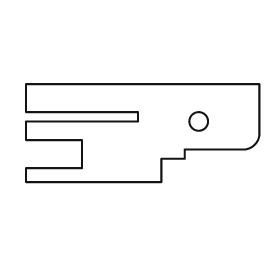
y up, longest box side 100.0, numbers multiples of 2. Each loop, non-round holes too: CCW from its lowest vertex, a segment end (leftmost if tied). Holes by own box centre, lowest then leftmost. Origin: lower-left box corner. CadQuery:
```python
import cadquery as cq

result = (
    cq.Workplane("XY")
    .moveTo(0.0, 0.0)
    .lineTo(58.0, 0.0)
    .lineTo(58.0, 10.0)
    .lineTo(68.0, 10.0)
    .lineTo(68.0, 14.0)
    .lineTo(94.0, 14.0)
    .threePointArc((98.0, 16.0), (100.0, 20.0))
    .lineTo(100.0, 42.0)
    .lineTo(0.0, 42.0)
    .lineTo(0.0, 30.0)
    .lineTo(48.0, 30.0)
    .lineTo(48.0, 26.0)
    .lineTo(0.0, 26.0)
    .lineTo(0.0, 18.0)
    .lineTo(24.0, 18.0)
    .lineTo(24.0, 6.0)
    .lineTo(0.0, 6.0)
    .close()
    .moveTo(74.0, 26.0)
    .circle(4.0)
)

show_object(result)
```